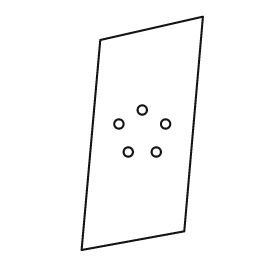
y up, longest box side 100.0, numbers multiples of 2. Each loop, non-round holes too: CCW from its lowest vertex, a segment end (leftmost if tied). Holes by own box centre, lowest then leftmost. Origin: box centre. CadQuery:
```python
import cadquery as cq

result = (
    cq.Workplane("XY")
    .moveTo(-26.0, -50.0)
    .lineTo(18.0, -42.0)
    .lineTo(26.0, 50.0)
    .lineTo(-18.0, 40.0)
    .close()
    .moveTo(-6.0, -8.0)
    .circle(2.0)
    .moveTo(6.0, -8.0)
    .circle(2.0)
    .moveTo(-10.0, 4.0)
    .circle(2.0)
    .moveTo(10.0, 4.0)
    .circle(2.0)
    .moveTo(0.0, 10.0)
    .circle(2.0)
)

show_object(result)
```